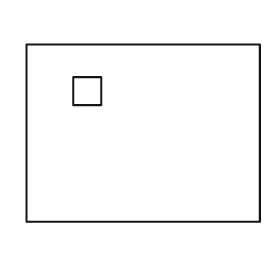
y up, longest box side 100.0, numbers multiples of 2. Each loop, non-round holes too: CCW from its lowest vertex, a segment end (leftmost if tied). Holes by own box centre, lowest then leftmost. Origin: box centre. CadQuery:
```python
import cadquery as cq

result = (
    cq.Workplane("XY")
    .moveTo(-50.0, -38.0)
    .lineTo(50.0, -38.0)
    .lineTo(50.0, 38.0)
    .lineTo(-50.0, 38.0)
    .close()
    .moveTo(-30.0, 12.0)
    .lineTo(-18.0, 12.0)
    .lineTo(-18.0, 24.0)
    .lineTo(-30.0, 24.0)
    .close()
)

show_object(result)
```